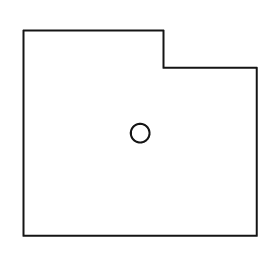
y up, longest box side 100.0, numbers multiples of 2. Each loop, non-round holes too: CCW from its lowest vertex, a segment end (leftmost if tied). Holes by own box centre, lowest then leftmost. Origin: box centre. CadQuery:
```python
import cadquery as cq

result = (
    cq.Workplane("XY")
    .moveTo(-50.0, -44.0)
    .lineTo(50.0, -44.0)
    .lineTo(50.0, 28.0)
    .lineTo(10.0, 28.0)
    .lineTo(10.0, 44.0)
    .lineTo(-50.0, 44.0)
    .close()
    .moveTo(0.0, 0.0)
    .circle(4.0)
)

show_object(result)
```